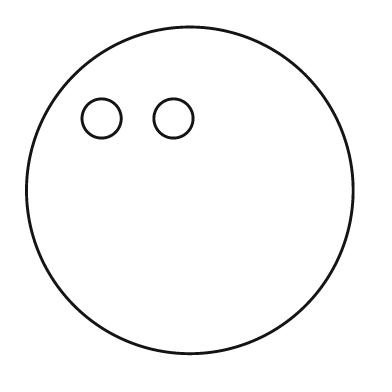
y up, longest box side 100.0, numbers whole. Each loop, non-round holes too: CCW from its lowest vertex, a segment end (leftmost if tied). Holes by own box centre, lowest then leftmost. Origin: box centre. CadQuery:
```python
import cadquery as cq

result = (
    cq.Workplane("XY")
    .moveTo(0.0, 0.0)
    .circle(50.0)
    .moveTo(-27.0, 22.0)
    .circle(6.0)
    .moveTo(-5.0, 22.0)
    .circle(6.0)
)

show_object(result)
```